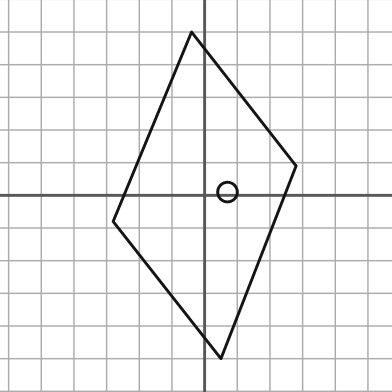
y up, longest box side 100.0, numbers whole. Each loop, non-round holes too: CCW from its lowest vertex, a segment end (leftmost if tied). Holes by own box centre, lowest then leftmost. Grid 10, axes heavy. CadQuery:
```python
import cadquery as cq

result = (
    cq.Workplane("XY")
    .moveTo(5.0, -50.0)
    .lineTo(28.0, 9.0)
    .lineTo(-4.0, 50.0)
    .lineTo(-28.0, -8.0)
    .close()
    .moveTo(7.0, 1.0)
    .circle(3.0)
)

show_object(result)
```